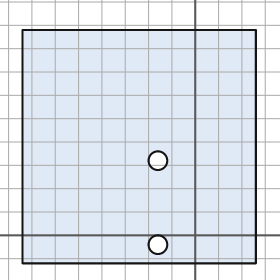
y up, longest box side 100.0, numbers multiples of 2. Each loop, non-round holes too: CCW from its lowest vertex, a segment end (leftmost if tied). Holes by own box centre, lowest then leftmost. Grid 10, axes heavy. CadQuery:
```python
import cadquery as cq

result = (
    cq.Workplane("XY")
    .moveTo(-74.0, -12.0)
    .lineTo(26.0, -12.0)
    .lineTo(26.0, 88.0)
    .lineTo(-74.0, 88.0)
    .close()
    .moveTo(-16.0, -4.0)
    .circle(4.0)
    .moveTo(-16.0, 32.0)
    .circle(4.0)
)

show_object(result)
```